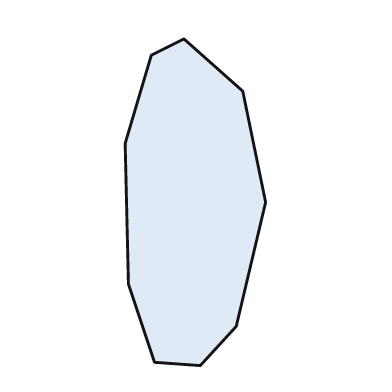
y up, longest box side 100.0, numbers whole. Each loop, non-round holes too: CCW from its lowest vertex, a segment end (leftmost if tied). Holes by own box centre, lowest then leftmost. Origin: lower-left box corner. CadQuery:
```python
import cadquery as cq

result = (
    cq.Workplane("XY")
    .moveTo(23.0, 0.0)
    .lineTo(34.0, 12.0)
    .lineTo(43.0, 50.0)
    .lineTo(36.0, 84.0)
    .lineTo(18.0, 100.0)
    .lineTo(8.0, 95.0)
    .lineTo(0.0, 68.0)
    .lineTo(1.0, 25.0)
    .lineTo(9.0, 1.0)
    .close()
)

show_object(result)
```